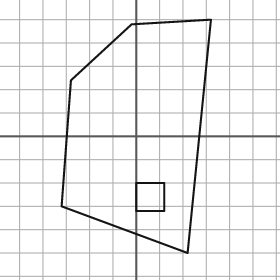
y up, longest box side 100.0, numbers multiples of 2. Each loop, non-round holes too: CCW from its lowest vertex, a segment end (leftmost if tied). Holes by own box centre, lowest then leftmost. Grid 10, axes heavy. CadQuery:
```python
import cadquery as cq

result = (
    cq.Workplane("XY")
    .moveTo(22.0, -50.0)
    .lineTo(32.0, 50.0)
    .lineTo(-2.0, 48.0)
    .lineTo(-28.0, 24.0)
    .lineTo(-32.0, -30.0)
    .close()
    .moveTo(0.0, -32.0)
    .lineTo(12.0, -32.0)
    .lineTo(12.0, -20.0)
    .lineTo(0.0, -20.0)
    .close()
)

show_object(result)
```